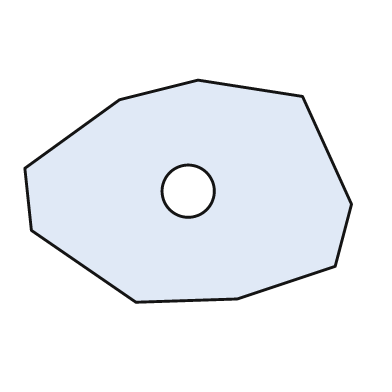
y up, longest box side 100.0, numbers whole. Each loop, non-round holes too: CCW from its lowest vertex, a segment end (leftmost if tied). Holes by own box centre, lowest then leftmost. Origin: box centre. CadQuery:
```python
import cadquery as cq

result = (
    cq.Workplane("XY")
    .moveTo(-16.0, -34.0)
    .lineTo(15.0, -33.0)
    .lineTo(45.0, -23.0)
    .lineTo(50.0, -4.0)
    .lineTo(35.0, 29.0)
    .lineTo(3.0, 34.0)
    .lineTo(-21.0, 28.0)
    .lineTo(-50.0, 7.0)
    .lineTo(-48.0, -12.0)
    .close()
    .moveTo(0.0, 0.0)
    .circle(8.0)
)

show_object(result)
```